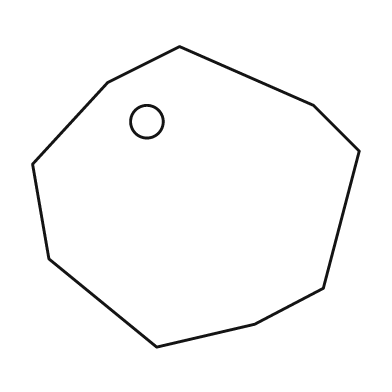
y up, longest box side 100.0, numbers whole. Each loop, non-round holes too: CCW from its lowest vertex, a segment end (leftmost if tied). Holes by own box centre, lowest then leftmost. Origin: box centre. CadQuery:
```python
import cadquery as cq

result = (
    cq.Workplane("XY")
    .moveTo(-12.0, -46.0)
    .lineTo(18.0, -39.0)
    .lineTo(39.0, -28.0)
    .lineTo(50.0, 14.0)
    .lineTo(36.0, 28.0)
    .lineTo(-5.0, 46.0)
    .lineTo(-27.0, 35.0)
    .lineTo(-50.0, 10.0)
    .lineTo(-45.0, -19.0)
    .close()
    .moveTo(-15.0, 23.0)
    .circle(5.0)
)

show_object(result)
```